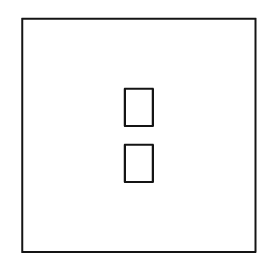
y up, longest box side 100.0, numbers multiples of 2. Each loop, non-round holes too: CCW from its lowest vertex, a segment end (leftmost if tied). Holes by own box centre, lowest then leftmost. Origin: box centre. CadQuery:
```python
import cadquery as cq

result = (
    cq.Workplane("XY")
    .moveTo(-50.0, -50.0)
    .lineTo(50.0, -50.0)
    .lineTo(50.0, 50.0)
    .lineTo(-50.0, 50.0)
    .close()
    .moveTo(-6.0, -20.0)
    .lineTo(6.0, -20.0)
    .lineTo(6.0, -4.0)
    .lineTo(-6.0, -4.0)
    .close()
    .moveTo(-6.0, 4.0)
    .lineTo(6.0, 4.0)
    .lineTo(6.0, 20.0)
    .lineTo(-6.0, 20.0)
    .close()
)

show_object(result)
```